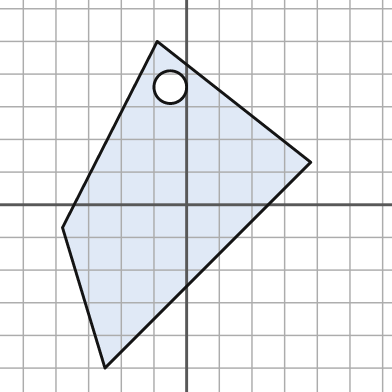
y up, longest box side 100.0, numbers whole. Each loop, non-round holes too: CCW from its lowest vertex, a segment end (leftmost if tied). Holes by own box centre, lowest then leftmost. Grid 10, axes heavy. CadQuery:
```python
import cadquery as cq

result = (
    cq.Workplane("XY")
    .moveTo(-25.0, -50.0)
    .lineTo(38.0, 13.0)
    .lineTo(-9.0, 50.0)
    .lineTo(-38.0, -7.0)
    .close()
    .moveTo(-5.0, 36.0)
    .circle(5.0)
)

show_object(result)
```